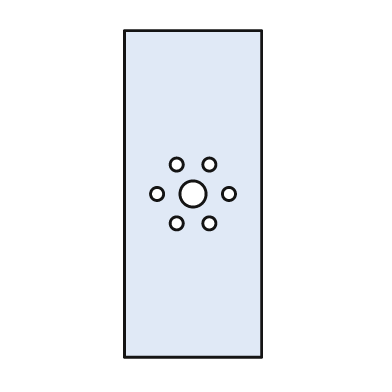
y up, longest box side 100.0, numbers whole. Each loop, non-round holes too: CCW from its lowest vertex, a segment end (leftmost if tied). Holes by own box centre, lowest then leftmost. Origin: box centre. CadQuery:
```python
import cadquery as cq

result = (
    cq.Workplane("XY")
    .moveTo(-21.0, -50.0)
    .lineTo(21.0, -50.0)
    .lineTo(21.0, 50.0)
    .lineTo(-21.0, 50.0)
    .close()
    .moveTo(-5.0, -9.0)
    .circle(2.0)
    .moveTo(5.0, -9.0)
    .circle(2.0)
    .moveTo(-11.0, 0.0)
    .circle(2.0)
    .moveTo(0.0, 0.0)
    .circle(4.0)
    .moveTo(11.0, 0.0)
    .circle(2.0)
    .moveTo(-5.0, 9.0)
    .circle(2.0)
    .moveTo(5.0, 9.0)
    .circle(2.0)
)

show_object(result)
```